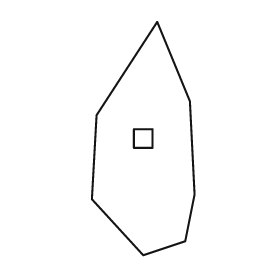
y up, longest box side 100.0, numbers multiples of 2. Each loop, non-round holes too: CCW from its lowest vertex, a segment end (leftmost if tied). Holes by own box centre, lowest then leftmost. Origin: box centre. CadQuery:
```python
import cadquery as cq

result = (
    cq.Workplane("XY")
    .moveTo(0.0, -50.0)
    .lineTo(18.0, -44.0)
    .lineTo(22.0, -24.0)
    .lineTo(20.0, 16.0)
    .lineTo(6.0, 50.0)
    .lineTo(-20.0, 10.0)
    .lineTo(-22.0, -26.0)
    .close()
    .moveTo(-4.0, -4.0)
    .lineTo(4.0, -4.0)
    .lineTo(4.0, 4.0)
    .lineTo(-4.0, 4.0)
    .close()
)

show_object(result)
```